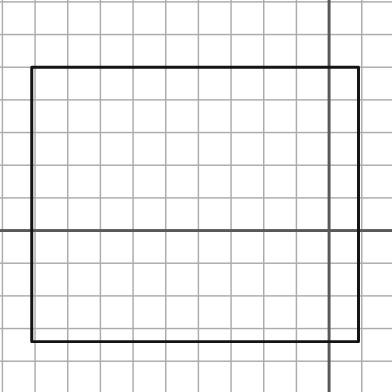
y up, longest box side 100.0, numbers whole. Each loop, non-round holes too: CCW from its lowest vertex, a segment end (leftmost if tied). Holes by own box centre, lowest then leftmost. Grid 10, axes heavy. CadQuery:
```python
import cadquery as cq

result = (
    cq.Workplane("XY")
    .moveTo(-91.0, -34.0)
    .lineTo(9.0, -34.0)
    .lineTo(9.0, 50.0)
    .lineTo(-91.0, 50.0)
    .close()
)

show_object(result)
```